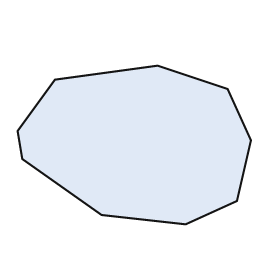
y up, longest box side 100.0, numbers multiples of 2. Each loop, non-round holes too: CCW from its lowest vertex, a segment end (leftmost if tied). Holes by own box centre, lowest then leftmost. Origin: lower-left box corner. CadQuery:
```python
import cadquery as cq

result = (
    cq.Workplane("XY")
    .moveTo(72.0, 0.0)
    .lineTo(94.0, 10.0)
    .lineTo(100.0, 36.0)
    .lineTo(90.0, 58.0)
    .lineTo(60.0, 68.0)
    .lineTo(16.0, 62.0)
    .lineTo(0.0, 40.0)
    .lineTo(2.0, 28.0)
    .lineTo(36.0, 4.0)
    .close()
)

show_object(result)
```